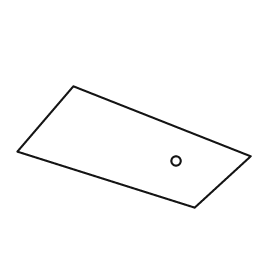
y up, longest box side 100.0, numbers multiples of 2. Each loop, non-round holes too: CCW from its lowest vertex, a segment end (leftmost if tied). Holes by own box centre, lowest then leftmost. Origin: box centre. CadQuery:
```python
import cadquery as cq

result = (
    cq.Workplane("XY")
    .moveTo(26.0, -26.0)
    .lineTo(50.0, -4.0)
    .lineTo(-26.0, 26.0)
    .lineTo(-50.0, -2.0)
    .close()
    .moveTo(18.0, -6.0)
    .circle(2.0)
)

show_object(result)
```